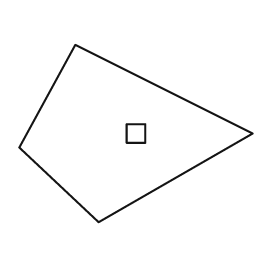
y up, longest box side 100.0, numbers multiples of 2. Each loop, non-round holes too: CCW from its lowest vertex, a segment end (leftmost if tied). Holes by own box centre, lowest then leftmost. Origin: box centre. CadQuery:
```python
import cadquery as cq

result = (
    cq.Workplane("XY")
    .moveTo(-16.0, -38.0)
    .lineTo(50.0, 0.0)
    .lineTo(-26.0, 38.0)
    .lineTo(-50.0, -6.0)
    .close()
    .moveTo(-4.0, -4.0)
    .lineTo(4.0, -4.0)
    .lineTo(4.0, 4.0)
    .lineTo(-4.0, 4.0)
    .close()
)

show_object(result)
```